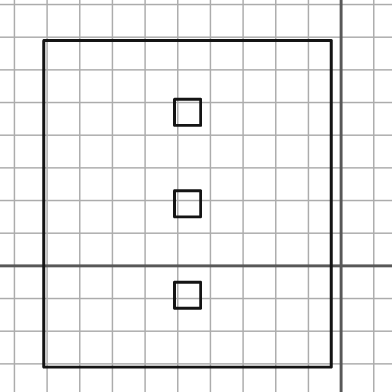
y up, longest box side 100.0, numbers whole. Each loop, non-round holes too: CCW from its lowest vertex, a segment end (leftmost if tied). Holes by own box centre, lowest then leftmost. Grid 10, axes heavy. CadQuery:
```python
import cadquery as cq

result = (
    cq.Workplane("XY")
    .moveTo(-91.0, -31.0)
    .lineTo(-3.0, -31.0)
    .lineTo(-3.0, 69.0)
    .lineTo(-91.0, 69.0)
    .close()
    .moveTo(-51.0, -13.0)
    .lineTo(-43.0, -13.0)
    .lineTo(-43.0, -5.0)
    .lineTo(-51.0, -5.0)
    .close()
    .moveTo(-51.0, 15.0)
    .lineTo(-43.0, 15.0)
    .lineTo(-43.0, 23.0)
    .lineTo(-51.0, 23.0)
    .close()
    .moveTo(-51.0, 43.0)
    .lineTo(-43.0, 43.0)
    .lineTo(-43.0, 51.0)
    .lineTo(-51.0, 51.0)
    .close()
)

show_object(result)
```